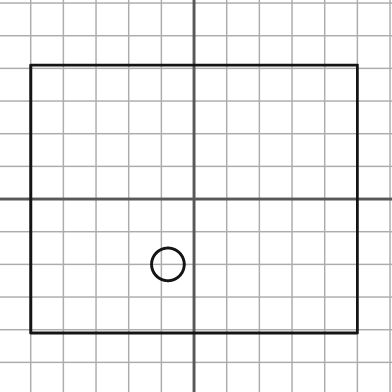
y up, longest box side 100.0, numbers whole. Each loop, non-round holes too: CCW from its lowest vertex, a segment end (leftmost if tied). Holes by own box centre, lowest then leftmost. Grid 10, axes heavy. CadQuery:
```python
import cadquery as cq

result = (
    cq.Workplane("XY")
    .moveTo(-50.0, -41.0)
    .lineTo(50.0, -41.0)
    .lineTo(50.0, 41.0)
    .lineTo(-50.0, 41.0)
    .close()
    .moveTo(-8.0, -20.0)
    .circle(5.0)
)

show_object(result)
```